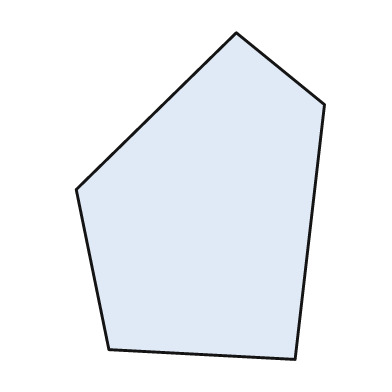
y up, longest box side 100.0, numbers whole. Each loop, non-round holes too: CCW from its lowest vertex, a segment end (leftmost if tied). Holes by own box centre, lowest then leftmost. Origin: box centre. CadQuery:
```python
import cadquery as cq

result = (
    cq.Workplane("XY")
    .moveTo(29.0, -50.0)
    .lineTo(38.0, 28.0)
    .lineTo(11.0, 50.0)
    .lineTo(-38.0, 2.0)
    .lineTo(-28.0, -47.0)
    .close()
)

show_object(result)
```